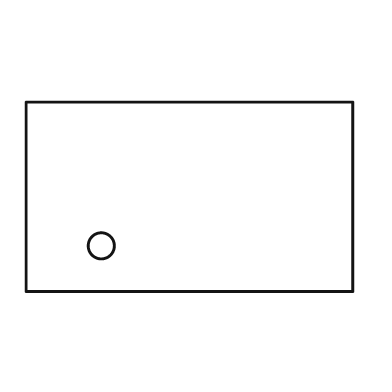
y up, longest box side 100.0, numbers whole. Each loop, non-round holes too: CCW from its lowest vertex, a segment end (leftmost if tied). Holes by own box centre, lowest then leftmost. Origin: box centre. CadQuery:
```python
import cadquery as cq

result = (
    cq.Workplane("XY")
    .moveTo(-50.0, -29.0)
    .lineTo(50.0, -29.0)
    .lineTo(50.0, 29.0)
    .lineTo(-50.0, 29.0)
    .close()
    .moveTo(-27.0, -15.0)
    .circle(4.0)
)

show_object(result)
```